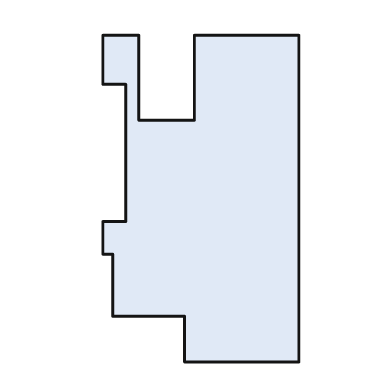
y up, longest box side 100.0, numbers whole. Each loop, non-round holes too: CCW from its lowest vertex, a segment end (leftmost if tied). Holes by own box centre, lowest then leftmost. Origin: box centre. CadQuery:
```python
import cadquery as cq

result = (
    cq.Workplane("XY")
    .moveTo(-5.0, -50.0)
    .lineTo(30.0, -50.0)
    .lineTo(30.0, 50.0)
    .lineTo(-2.0, 50.0)
    .lineTo(-2.0, 24.0)
    .lineTo(-19.0, 24.0)
    .lineTo(-19.0, 50.0)
    .lineTo(-30.0, 50.0)
    .lineTo(-30.0, 35.0)
    .lineTo(-23.0, 35.0)
    .lineTo(-23.0, -7.0)
    .lineTo(-30.0, -7.0)
    .lineTo(-30.0, -17.0)
    .lineTo(-27.0, -17.0)
    .lineTo(-27.0, -36.0)
    .lineTo(-5.0, -36.0)
    .close()
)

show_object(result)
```